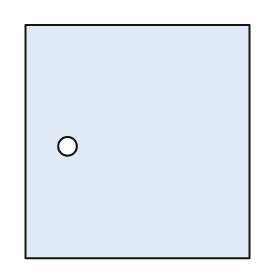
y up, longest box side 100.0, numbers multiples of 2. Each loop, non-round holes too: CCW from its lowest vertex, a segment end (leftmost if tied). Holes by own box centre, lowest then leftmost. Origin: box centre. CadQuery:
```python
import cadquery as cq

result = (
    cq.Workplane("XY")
    .moveTo(-48.0, -50.0)
    .lineTo(48.0, -50.0)
    .lineTo(48.0, 50.0)
    .lineTo(-48.0, 50.0)
    .close()
    .moveTo(-30.0, -2.0)
    .circle(4.0)
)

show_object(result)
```